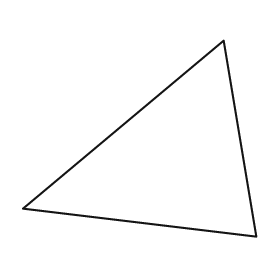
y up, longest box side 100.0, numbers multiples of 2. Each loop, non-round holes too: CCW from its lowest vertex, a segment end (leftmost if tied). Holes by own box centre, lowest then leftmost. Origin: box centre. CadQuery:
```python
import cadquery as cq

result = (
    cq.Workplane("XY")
    .moveTo(50.0, -42.0)
    .lineTo(36.0, 42.0)
    .lineTo(-50.0, -30.0)
    .close()
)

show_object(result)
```